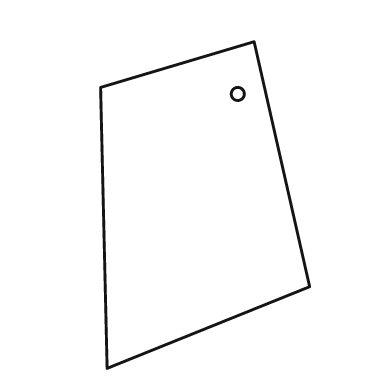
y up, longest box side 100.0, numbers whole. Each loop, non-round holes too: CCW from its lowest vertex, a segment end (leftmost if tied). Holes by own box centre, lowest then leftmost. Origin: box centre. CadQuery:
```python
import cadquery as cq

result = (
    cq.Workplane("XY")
    .moveTo(-30.0, -50.0)
    .lineTo(32.0, -25.0)
    .lineTo(15.0, 50.0)
    .lineTo(-32.0, 36.0)
    .close()
    .moveTo(10.0, 34.0)
    .circle(2.0)
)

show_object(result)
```